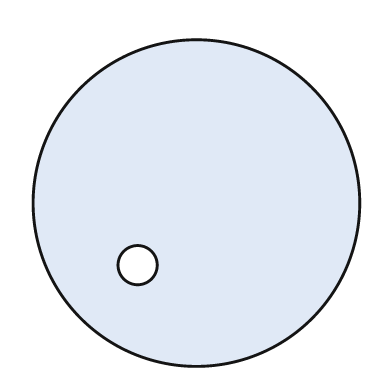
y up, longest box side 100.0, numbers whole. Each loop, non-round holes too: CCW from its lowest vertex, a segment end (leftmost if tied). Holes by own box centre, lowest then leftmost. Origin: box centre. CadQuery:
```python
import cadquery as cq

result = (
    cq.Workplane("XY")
    .moveTo(0.0, 0.0)
    .circle(50.0)
    .moveTo(-18.0, -19.0)
    .circle(6.0)
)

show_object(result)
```